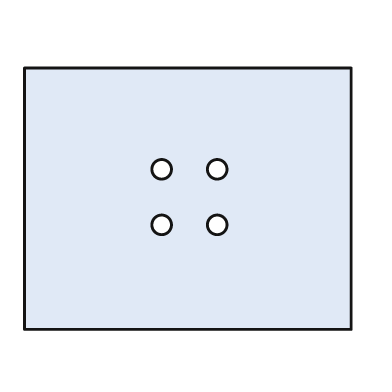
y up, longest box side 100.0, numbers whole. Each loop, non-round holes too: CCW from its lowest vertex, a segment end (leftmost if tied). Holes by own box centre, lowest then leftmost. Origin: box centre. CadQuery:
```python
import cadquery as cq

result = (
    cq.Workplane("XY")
    .moveTo(-50.0, -40.0)
    .lineTo(50.0, -40.0)
    .lineTo(50.0, 40.0)
    .lineTo(-50.0, 40.0)
    .close()
    .moveTo(-8.0, -8.0)
    .circle(3.0)
    .moveTo(9.0, -8.0)
    .circle(3.0)
    .moveTo(-8.0, 9.0)
    .circle(3.0)
    .moveTo(9.0, 9.0)
    .circle(3.0)
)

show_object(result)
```